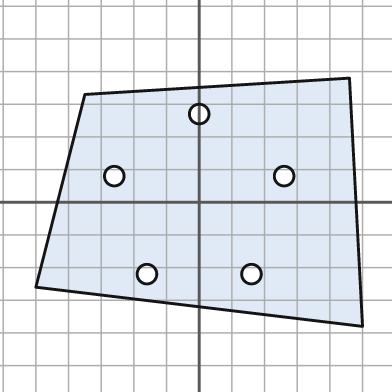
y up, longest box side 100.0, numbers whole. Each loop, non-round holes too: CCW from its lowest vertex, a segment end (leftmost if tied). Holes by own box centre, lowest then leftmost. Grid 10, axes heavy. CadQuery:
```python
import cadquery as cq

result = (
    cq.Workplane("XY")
    .moveTo(50.0, -38.0)
    .lineTo(46.0, 38.0)
    .lineTo(-35.0, 33.0)
    .lineTo(-50.0, -26.0)
    .close()
    .moveTo(-16.0, -22.0)
    .circle(3.0)
    .moveTo(16.0, -22.0)
    .circle(3.0)
    .moveTo(-26.0, 8.0)
    .circle(3.0)
    .moveTo(26.0, 8.0)
    .circle(3.0)
    .moveTo(0.0, 27.0)
    .circle(3.0)
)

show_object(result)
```